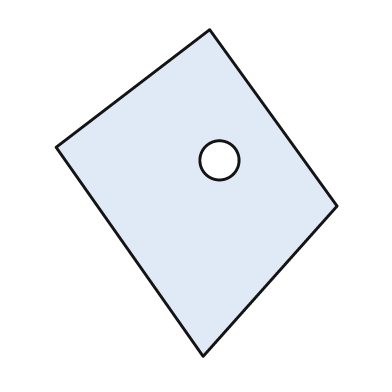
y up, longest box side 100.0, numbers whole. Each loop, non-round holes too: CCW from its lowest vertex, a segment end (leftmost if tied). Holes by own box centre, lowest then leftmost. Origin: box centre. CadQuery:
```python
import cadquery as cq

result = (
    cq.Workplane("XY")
    .moveTo(2.0, -50.0)
    .lineTo(43.0, -4.0)
    .lineTo(4.0, 50.0)
    .lineTo(-43.0, 14.0)
    .close()
    .moveTo(7.0, 10.0)
    .circle(6.0)
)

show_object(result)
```